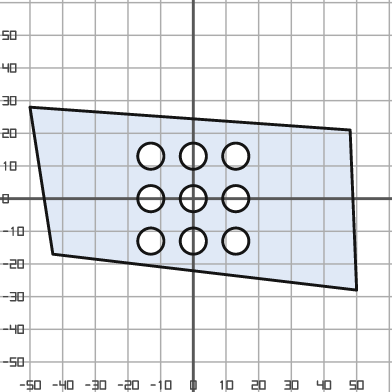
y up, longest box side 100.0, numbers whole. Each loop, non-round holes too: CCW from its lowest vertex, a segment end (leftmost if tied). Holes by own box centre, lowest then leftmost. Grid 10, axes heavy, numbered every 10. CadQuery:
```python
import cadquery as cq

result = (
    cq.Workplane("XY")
    .moveTo(50.0, -28.0)
    .lineTo(48.0, 21.0)
    .lineTo(-50.0, 28.0)
    .lineTo(-43.0, -17.0)
    .close()
    .moveTo(-13.0, -13.0)
    .circle(4.0)
    .moveTo(0.0, -13.0)
    .circle(4.0)
    .moveTo(13.0, -13.0)
    .circle(4.0)
    .moveTo(-13.0, 0.0)
    .circle(4.0)
    .moveTo(0.0, 0.0)
    .circle(4.0)
    .moveTo(13.0, 0.0)
    .circle(4.0)
    .moveTo(-13.0, 13.0)
    .circle(4.0)
    .moveTo(0.0, 13.0)
    .circle(4.0)
    .moveTo(13.0, 13.0)
    .circle(4.0)
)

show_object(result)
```